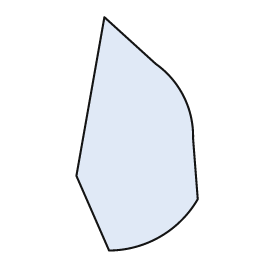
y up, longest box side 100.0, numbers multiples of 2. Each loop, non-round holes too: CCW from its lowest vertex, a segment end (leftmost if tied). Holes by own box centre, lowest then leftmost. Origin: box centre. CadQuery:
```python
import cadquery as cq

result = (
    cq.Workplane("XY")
    .moveTo(-12.0, -50.0)
    .threePointArc((10.0, -44.0), (26.0, -28.0))
    .lineTo(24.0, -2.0)
    .threePointArc((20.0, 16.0), (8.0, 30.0))
    .lineTo(-14.0, 50.0)
    .lineTo(-26.0, -18.0)
    .close()
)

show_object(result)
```